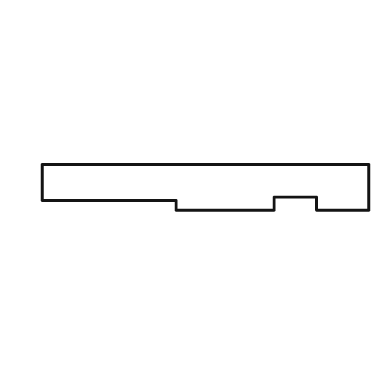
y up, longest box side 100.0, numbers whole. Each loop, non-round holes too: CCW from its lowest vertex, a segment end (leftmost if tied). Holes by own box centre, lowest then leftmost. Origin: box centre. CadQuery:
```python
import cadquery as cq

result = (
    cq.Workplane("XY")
    .moveTo(-9.0, -7.0)
    .lineTo(21.0, -7.0)
    .lineTo(21.0, -3.0)
    .lineTo(34.0, -3.0)
    .lineTo(34.0, -7.0)
    .lineTo(50.0, -7.0)
    .lineTo(50.0, 7.0)
    .lineTo(-50.0, 7.0)
    .lineTo(-50.0, -4.0)
    .lineTo(-9.0, -4.0)
    .close()
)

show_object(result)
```